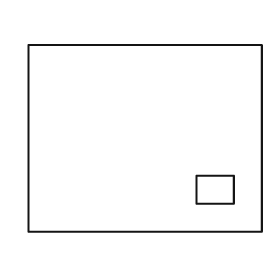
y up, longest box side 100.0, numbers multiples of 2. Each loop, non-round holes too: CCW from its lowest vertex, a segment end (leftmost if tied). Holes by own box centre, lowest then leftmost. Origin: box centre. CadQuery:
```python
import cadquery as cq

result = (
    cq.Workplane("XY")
    .moveTo(-50.0, -40.0)
    .lineTo(50.0, -40.0)
    .lineTo(50.0, 40.0)
    .lineTo(-50.0, 40.0)
    .close()
    .moveTo(22.0, -28.0)
    .lineTo(38.0, -28.0)
    .lineTo(38.0, -16.0)
    .lineTo(22.0, -16.0)
    .close()
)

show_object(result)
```